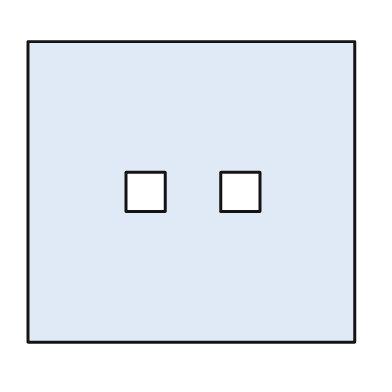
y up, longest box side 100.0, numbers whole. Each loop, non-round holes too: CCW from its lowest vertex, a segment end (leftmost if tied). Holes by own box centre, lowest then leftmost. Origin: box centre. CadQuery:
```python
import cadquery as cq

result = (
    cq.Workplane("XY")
    .moveTo(-50.0, -46.0)
    .lineTo(50.0, -46.0)
    .lineTo(50.0, 46.0)
    .lineTo(-50.0, 46.0)
    .close()
    .moveTo(-20.0, -6.0)
    .lineTo(-8.0, -6.0)
    .lineTo(-8.0, 6.0)
    .lineTo(-20.0, 6.0)
    .close()
    .moveTo(9.0, -6.0)
    .lineTo(21.0, -6.0)
    .lineTo(21.0, 6.0)
    .lineTo(9.0, 6.0)
    .close()
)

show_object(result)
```